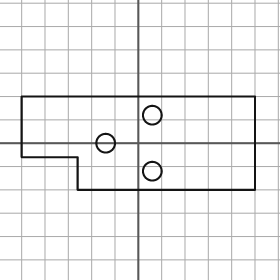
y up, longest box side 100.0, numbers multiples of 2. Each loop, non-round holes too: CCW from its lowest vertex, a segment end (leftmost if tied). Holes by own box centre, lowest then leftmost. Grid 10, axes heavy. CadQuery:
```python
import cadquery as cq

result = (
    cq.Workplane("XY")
    .moveTo(-26.0, -20.0)
    .lineTo(50.0, -20.0)
    .lineTo(50.0, 20.0)
    .lineTo(-50.0, 20.0)
    .lineTo(-50.0, -6.0)
    .lineTo(-26.0, -6.0)
    .close()
    .moveTo(6.0, -12.0)
    .circle(4.0)
    .moveTo(-14.0, 0.0)
    .circle(4.0)
    .moveTo(6.0, 12.0)
    .circle(4.0)
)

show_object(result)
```